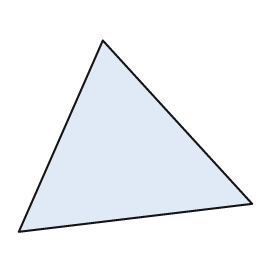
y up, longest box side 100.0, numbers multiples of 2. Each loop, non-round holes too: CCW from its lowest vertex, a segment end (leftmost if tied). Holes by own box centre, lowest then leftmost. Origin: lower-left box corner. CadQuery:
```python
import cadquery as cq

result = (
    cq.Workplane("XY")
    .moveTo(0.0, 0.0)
    .lineTo(100.0, 12.0)
    .lineTo(36.0, 82.0)
    .close()
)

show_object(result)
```